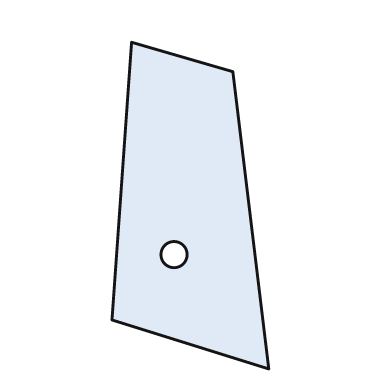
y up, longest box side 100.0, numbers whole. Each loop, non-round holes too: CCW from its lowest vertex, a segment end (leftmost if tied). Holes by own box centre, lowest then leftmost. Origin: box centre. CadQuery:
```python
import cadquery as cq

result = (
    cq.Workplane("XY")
    .moveTo(24.0, -50.0)
    .lineTo(13.0, 41.0)
    .lineTo(-18.0, 50.0)
    .lineTo(-24.0, -35.0)
    .close()
    .moveTo(-5.0, -15.0)
    .circle(4.0)
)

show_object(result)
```